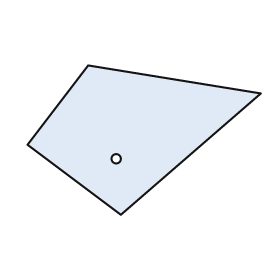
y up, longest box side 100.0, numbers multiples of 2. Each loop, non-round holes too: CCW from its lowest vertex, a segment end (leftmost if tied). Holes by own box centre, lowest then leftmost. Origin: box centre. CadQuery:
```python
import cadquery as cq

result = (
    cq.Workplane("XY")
    .moveTo(-10.0, -32.0)
    .lineTo(50.0, 20.0)
    .lineTo(-24.0, 32.0)
    .lineTo(-50.0, -2.0)
    .close()
    .moveTo(-12.0, -8.0)
    .circle(2.0)
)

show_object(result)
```